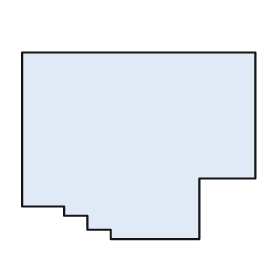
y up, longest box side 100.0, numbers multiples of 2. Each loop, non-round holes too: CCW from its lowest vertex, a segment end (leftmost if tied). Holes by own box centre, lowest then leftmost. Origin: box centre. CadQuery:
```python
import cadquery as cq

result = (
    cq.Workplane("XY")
    .moveTo(-12.0, -40.0)
    .lineTo(26.0, -40.0)
    .lineTo(26.0, -14.0)
    .lineTo(50.0, -14.0)
    .lineTo(50.0, 40.0)
    .lineTo(-50.0, 40.0)
    .lineTo(-50.0, -26.0)
    .lineTo(-32.0, -26.0)
    .lineTo(-32.0, -30.0)
    .lineTo(-22.0, -30.0)
    .lineTo(-22.0, -36.0)
    .lineTo(-12.0, -36.0)
    .close()
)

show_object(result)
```